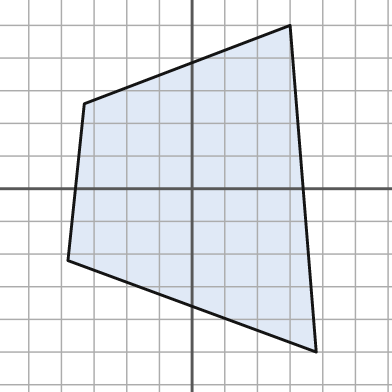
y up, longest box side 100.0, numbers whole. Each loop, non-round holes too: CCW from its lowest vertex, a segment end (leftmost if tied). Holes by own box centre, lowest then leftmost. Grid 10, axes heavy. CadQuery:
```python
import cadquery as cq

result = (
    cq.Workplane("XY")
    .moveTo(38.0, -50.0)
    .lineTo(30.0, 50.0)
    .lineTo(-33.0, 26.0)
    .lineTo(-38.0, -22.0)
    .close()
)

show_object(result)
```